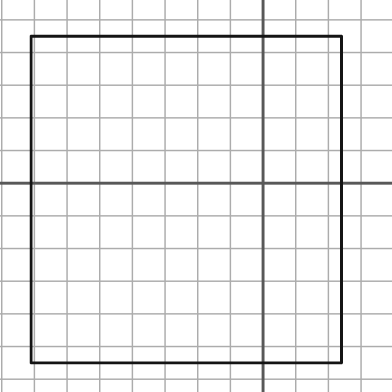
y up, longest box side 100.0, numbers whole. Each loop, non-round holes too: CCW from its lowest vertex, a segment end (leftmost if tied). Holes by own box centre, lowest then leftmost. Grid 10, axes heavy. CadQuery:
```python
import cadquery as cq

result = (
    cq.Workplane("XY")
    .moveTo(-71.0, -55.0)
    .lineTo(24.0, -55.0)
    .lineTo(24.0, 45.0)
    .lineTo(-71.0, 45.0)
    .close()
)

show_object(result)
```